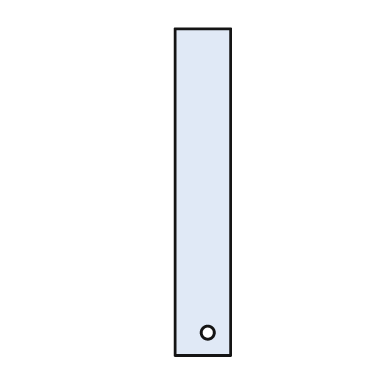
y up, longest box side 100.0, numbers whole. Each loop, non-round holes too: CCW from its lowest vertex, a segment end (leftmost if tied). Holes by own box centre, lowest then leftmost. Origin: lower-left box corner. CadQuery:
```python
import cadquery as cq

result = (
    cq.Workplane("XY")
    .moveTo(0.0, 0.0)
    .lineTo(17.0, 0.0)
    .lineTo(17.0, 100.0)
    .lineTo(0.0, 100.0)
    .close()
    .moveTo(10.0, 7.0)
    .circle(2.0)
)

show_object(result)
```